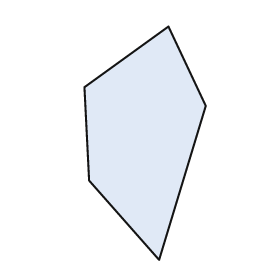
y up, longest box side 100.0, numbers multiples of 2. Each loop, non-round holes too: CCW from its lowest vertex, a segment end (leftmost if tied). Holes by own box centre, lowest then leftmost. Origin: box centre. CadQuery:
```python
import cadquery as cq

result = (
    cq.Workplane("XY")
    .moveTo(6.0, -50.0)
    .lineTo(26.0, 16.0)
    .lineTo(10.0, 50.0)
    .lineTo(-26.0, 24.0)
    .lineTo(-24.0, -16.0)
    .close()
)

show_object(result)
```